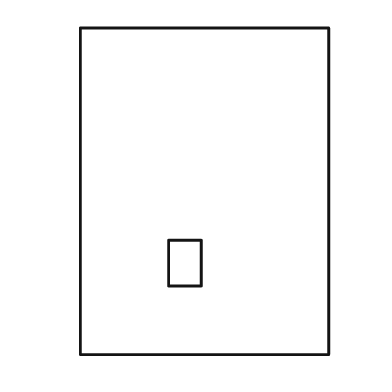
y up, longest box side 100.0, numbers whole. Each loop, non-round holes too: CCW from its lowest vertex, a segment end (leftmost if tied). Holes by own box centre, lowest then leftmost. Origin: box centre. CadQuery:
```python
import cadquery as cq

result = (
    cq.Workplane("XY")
    .moveTo(-38.0, -50.0)
    .lineTo(38.0, -50.0)
    .lineTo(38.0, 50.0)
    .lineTo(-38.0, 50.0)
    .close()
    .moveTo(-11.0, -29.0)
    .lineTo(-1.0, -29.0)
    .lineTo(-1.0, -15.0)
    .lineTo(-11.0, -15.0)
    .close()
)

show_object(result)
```